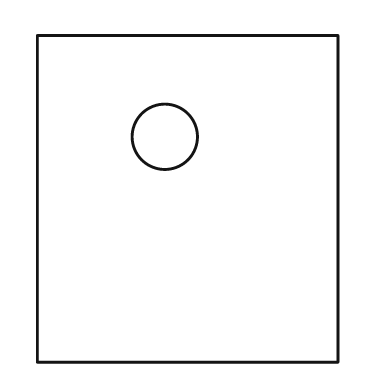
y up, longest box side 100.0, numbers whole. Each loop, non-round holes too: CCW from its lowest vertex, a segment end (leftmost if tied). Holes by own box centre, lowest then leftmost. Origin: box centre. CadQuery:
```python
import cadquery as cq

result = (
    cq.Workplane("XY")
    .moveTo(-46.0, -50.0)
    .lineTo(46.0, -50.0)
    .lineTo(46.0, 50.0)
    .lineTo(-46.0, 50.0)
    .close()
    .moveTo(-7.0, 19.0)
    .circle(10.0)
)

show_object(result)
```